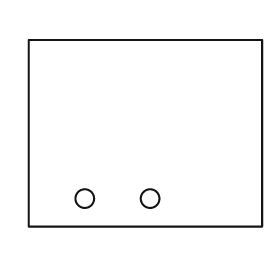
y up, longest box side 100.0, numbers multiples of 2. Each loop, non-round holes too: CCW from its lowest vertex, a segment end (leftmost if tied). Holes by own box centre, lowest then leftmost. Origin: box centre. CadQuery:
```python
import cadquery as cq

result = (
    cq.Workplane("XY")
    .moveTo(-50.0, -40.0)
    .lineTo(50.0, -40.0)
    .lineTo(50.0, 40.0)
    .lineTo(-50.0, 40.0)
    .close()
    .moveTo(-26.0, -28.0)
    .circle(4.0)
    .moveTo(2.0, -28.0)
    .circle(4.0)
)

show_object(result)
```